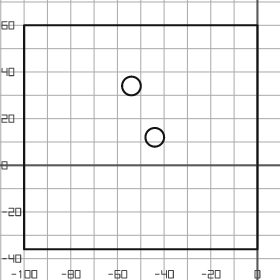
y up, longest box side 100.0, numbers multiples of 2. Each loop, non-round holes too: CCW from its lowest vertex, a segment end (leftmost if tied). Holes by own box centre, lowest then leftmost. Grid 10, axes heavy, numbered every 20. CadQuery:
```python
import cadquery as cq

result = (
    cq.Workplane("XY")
    .moveTo(-100.0, -36.0)
    .lineTo(0.0, -36.0)
    .lineTo(0.0, 60.0)
    .lineTo(-100.0, 60.0)
    .close()
    .moveTo(-44.0, 12.0)
    .circle(4.0)
    .moveTo(-54.0, 34.0)
    .circle(4.0)
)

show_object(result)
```